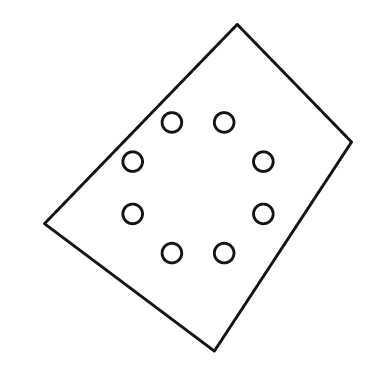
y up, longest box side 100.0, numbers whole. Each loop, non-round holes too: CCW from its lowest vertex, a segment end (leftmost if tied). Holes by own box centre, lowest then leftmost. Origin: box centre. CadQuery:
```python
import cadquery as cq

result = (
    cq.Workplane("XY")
    .moveTo(5.0, -50.0)
    .lineTo(47.0, 14.0)
    .lineTo(12.0, 50.0)
    .lineTo(-47.0, -11.0)
    .close()
    .moveTo(-8.0, -20.0)
    .circle(3.0)
    .moveTo(8.0, -20.0)
    .circle(3.0)
    .moveTo(-20.0, -8.0)
    .circle(3.0)
    .moveTo(20.0, -8.0)
    .circle(3.0)
    .moveTo(-20.0, 8.0)
    .circle(3.0)
    .moveTo(20.0, 8.0)
    .circle(3.0)
    .moveTo(-8.0, 20.0)
    .circle(3.0)
    .moveTo(8.0, 20.0)
    .circle(3.0)
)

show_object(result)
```